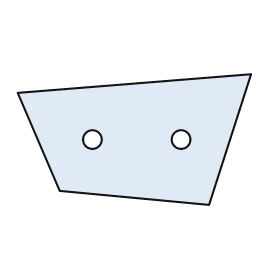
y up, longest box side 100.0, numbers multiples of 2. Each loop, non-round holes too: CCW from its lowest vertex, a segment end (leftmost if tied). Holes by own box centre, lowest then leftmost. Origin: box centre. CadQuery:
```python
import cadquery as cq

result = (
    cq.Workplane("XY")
    .moveTo(32.0, -28.0)
    .lineTo(50.0, 28.0)
    .lineTo(-50.0, 20.0)
    .lineTo(-32.0, -22.0)
    .close()
    .moveTo(-18.0, 0.0)
    .circle(4.0)
    .moveTo(20.0, 0.0)
    .circle(4.0)
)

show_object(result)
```